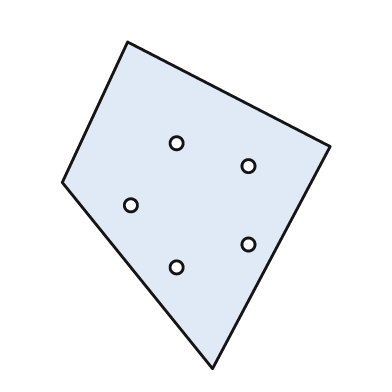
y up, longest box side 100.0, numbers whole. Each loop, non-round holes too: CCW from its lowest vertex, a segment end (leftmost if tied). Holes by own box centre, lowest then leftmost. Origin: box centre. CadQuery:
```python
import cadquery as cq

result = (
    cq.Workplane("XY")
    .moveTo(5.0, -50.0)
    .lineTo(41.0, 18.0)
    .lineTo(-21.0, 50.0)
    .lineTo(-41.0, 7.0)
    .close()
    .moveTo(-6.0, -19.0)
    .circle(2.0)
    .moveTo(16.0, -12.0)
    .circle(2.0)
    .moveTo(-20.0, 0.0)
    .circle(2.0)
    .moveTo(16.0, 12.0)
    .circle(2.0)
    .moveTo(-6.0, 19.0)
    .circle(2.0)
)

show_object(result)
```